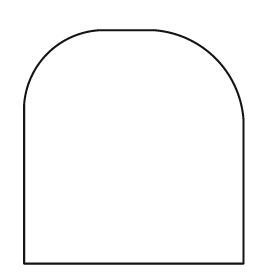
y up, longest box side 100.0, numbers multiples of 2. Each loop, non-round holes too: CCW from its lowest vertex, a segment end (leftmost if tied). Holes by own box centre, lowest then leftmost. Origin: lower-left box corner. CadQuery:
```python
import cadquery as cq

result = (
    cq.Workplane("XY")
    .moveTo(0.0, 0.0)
    .lineTo(94.0, 0.0)
    .lineTo(94.0, 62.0)
    .threePointArc((82.0, 88.0), (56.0, 100.0))
    .lineTo(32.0, 100.0)
    .threePointArc((10.0, 90.0), (0.0, 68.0))
    .close()
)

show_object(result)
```